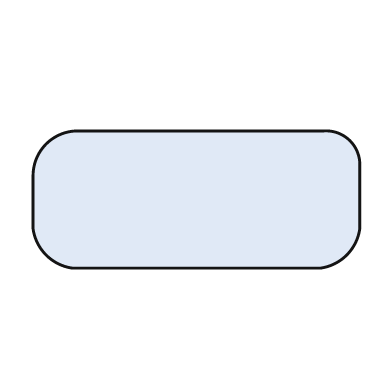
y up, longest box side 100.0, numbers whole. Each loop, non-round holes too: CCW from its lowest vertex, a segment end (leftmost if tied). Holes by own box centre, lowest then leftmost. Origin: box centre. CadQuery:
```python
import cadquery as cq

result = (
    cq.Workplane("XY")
    .moveTo(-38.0, -21.0)
    .lineTo(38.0, -21.0)
    .threePointArc((46.0, -17.0), (50.0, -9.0))
    .lineTo(50.0, 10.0)
    .threePointArc((47.0, 18.0), (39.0, 21.0))
    .lineTo(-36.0, 21.0)
    .threePointArc((-46.0, 17.0), (-50.0, 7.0))
    .lineTo(-50.0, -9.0)
    .threePointArc((-46.0, -17.0), (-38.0, -21.0))
    .close()
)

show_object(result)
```